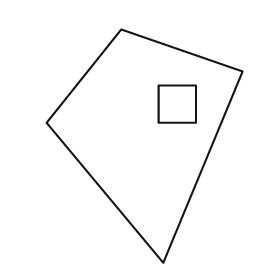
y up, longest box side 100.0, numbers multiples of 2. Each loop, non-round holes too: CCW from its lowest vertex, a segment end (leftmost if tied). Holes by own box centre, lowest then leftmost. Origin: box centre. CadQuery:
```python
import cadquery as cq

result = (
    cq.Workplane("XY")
    .moveTo(8.0, -50.0)
    .lineTo(42.0, 32.0)
    .lineTo(-10.0, 50.0)
    .lineTo(-42.0, 10.0)
    .close()
    .moveTo(6.0, 10.0)
    .lineTo(22.0, 10.0)
    .lineTo(22.0, 26.0)
    .lineTo(6.0, 26.0)
    .close()
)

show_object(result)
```